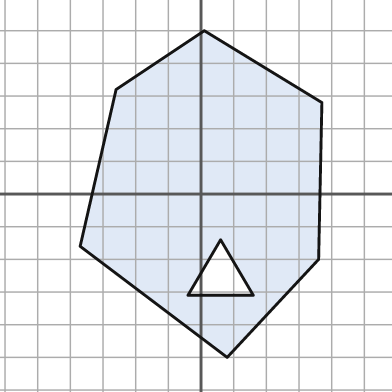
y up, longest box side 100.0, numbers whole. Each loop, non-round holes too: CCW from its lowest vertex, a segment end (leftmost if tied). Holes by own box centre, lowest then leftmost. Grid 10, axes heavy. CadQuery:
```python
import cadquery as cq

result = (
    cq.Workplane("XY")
    .moveTo(8.0, -50.0)
    .lineTo(36.0, -20.0)
    .lineTo(37.0, 28.0)
    .lineTo(1.0, 50.0)
    .lineTo(-26.0, 32.0)
    .lineTo(-37.0, -16.0)
    .close()
    .moveTo(-4.0, -31.0)
    .lineTo(16.0, -31.0)
    .lineTo(6.0, -14.0)
    .close()
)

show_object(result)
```